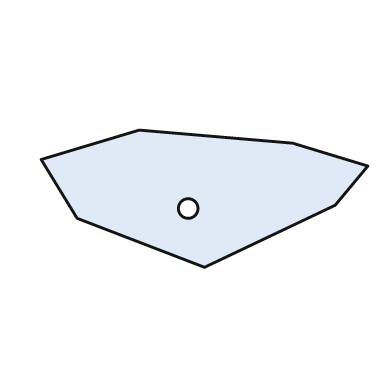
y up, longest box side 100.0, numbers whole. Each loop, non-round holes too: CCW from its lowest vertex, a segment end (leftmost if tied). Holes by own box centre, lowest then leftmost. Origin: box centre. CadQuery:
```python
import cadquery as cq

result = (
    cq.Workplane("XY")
    .moveTo(0.0, -21.0)
    .lineTo(40.0, -2.0)
    .lineTo(50.0, 10.0)
    .lineTo(27.0, 17.0)
    .lineTo(-20.0, 21.0)
    .lineTo(-50.0, 12.0)
    .lineTo(-39.0, -6.0)
    .close()
    .moveTo(-5.0, -3.0)
    .circle(3.0)
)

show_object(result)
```